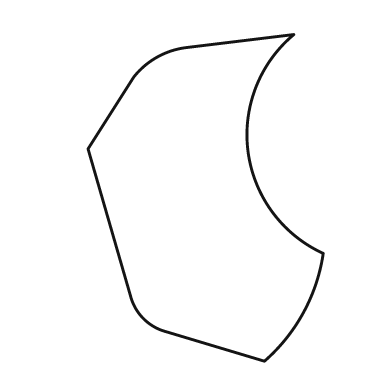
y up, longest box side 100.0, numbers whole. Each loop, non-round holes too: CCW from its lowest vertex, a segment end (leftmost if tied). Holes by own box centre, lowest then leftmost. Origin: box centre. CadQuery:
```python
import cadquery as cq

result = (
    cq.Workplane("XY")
    .moveTo(18.0, -50.0)
    .threePointArc((30.0, -35.0), (36.0, -17.0))
    .threePointArc((13.0, 14.0), (27.0, 50.0))
    .lineTo(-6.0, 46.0)
    .threePointArc((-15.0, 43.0), (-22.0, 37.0))
    .lineTo(-36.0, 15.0)
    .lineTo(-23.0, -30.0)
    .threePointArc((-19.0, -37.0), (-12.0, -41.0))
    .close()
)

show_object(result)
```